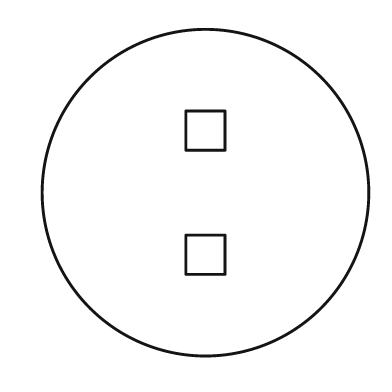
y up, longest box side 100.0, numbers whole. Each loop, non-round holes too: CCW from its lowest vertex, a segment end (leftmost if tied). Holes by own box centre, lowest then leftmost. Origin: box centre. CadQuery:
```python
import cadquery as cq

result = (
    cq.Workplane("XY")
    .moveTo(0.0, 0.0)
    .circle(50.0)
    .moveTo(-6.0, -25.0)
    .lineTo(6.0, -25.0)
    .lineTo(6.0, -13.0)
    .lineTo(-6.0, -13.0)
    .close()
    .moveTo(-6.0, 13.0)
    .lineTo(6.0, 13.0)
    .lineTo(6.0, 25.0)
    .lineTo(-6.0, 25.0)
    .close()
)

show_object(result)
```